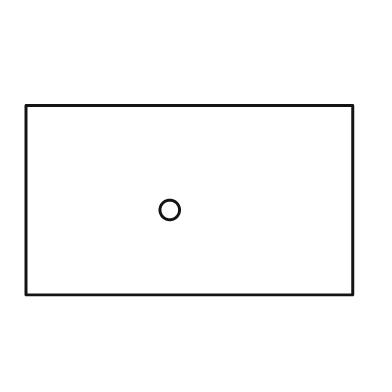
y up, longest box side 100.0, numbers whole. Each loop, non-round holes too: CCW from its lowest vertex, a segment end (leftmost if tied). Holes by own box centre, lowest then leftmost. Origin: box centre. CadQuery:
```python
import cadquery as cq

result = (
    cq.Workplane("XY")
    .moveTo(-50.0, -29.0)
    .lineTo(50.0, -29.0)
    .lineTo(50.0, 29.0)
    .lineTo(-50.0, 29.0)
    .close()
    .moveTo(-6.0, -3.0)
    .circle(3.0)
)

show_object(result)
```